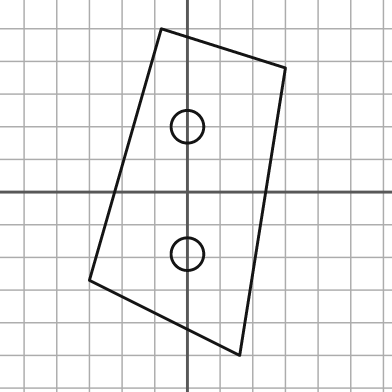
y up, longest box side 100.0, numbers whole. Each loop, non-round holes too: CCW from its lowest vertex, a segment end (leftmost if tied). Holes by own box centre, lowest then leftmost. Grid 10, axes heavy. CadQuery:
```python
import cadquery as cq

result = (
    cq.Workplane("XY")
    .moveTo(16.0, -50.0)
    .lineTo(30.0, 38.0)
    .lineTo(-8.0, 50.0)
    .lineTo(-30.0, -27.0)
    .close()
    .moveTo(0.0, -19.0)
    .circle(5.0)
    .moveTo(0.0, 20.0)
    .circle(5.0)
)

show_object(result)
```